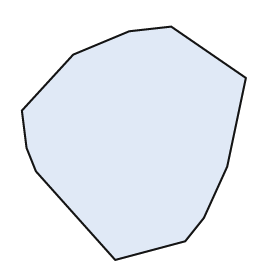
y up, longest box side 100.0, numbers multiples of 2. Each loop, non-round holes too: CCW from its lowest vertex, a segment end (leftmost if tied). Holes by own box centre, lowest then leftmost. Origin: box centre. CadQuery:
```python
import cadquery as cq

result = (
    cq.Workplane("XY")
    .moveTo(-8.0, -50.0)
    .lineTo(22.0, -42.0)
    .lineTo(30.0, -32.0)
    .lineTo(40.0, -10.0)
    .lineTo(48.0, 28.0)
    .lineTo(16.0, 50.0)
    .lineTo(-2.0, 48.0)
    .lineTo(-26.0, 38.0)
    .lineTo(-48.0, 14.0)
    .lineTo(-46.0, -2.0)
    .lineTo(-42.0, -12.0)
    .close()
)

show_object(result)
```